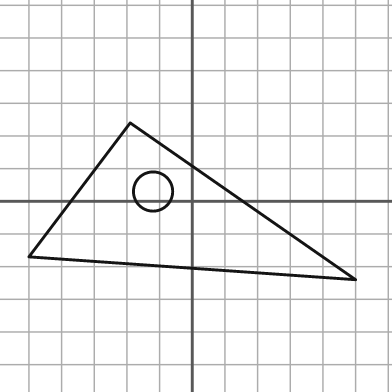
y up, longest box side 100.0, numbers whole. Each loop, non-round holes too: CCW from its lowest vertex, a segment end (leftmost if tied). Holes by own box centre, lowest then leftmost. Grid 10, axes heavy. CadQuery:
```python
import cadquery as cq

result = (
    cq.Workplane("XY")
    .moveTo(50.0, -24.0)
    .lineTo(-19.0, 24.0)
    .lineTo(-50.0, -17.0)
    .close()
    .moveTo(-12.0, 3.0)
    .circle(6.0)
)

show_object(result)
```